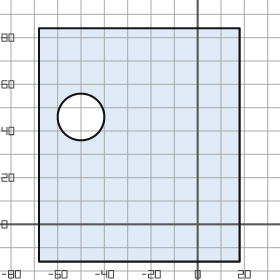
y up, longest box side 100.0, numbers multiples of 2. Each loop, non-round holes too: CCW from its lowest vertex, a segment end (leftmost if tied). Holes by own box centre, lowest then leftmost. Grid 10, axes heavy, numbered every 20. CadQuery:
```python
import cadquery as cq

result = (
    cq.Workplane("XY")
    .moveTo(-68.0, -16.0)
    .lineTo(18.0, -16.0)
    .lineTo(18.0, 84.0)
    .lineTo(-68.0, 84.0)
    .close()
    .moveTo(-50.0, 46.0)
    .circle(10.0)
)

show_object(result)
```